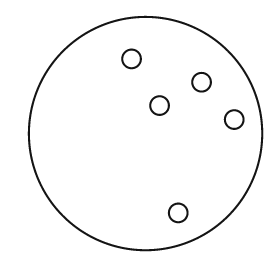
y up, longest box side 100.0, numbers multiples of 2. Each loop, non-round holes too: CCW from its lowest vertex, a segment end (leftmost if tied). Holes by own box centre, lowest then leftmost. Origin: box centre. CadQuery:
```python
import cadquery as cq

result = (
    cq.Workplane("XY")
    .moveTo(0.0, 0.0)
    .circle(50.0)
    .moveTo(14.0, -34.0)
    .circle(4.0)
    .moveTo(38.0, 6.0)
    .circle(4.0)
    .moveTo(6.0, 12.0)
    .circle(4.0)
    .moveTo(24.0, 22.0)
    .circle(4.0)
    .moveTo(-6.0, 32.0)
    .circle(4.0)
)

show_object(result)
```